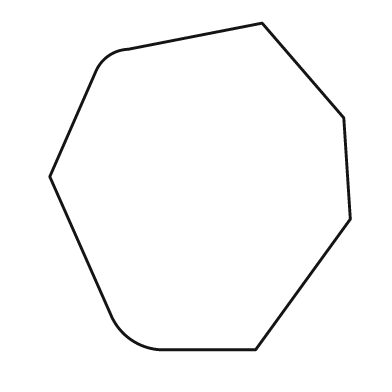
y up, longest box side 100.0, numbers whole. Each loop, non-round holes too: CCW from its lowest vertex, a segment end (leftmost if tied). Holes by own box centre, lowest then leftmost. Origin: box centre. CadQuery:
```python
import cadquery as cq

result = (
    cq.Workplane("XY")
    .moveTo(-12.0, -50.0)
    .lineTo(17.0, -50.0)
    .lineTo(46.0, -10.0)
    .lineTo(44.0, 21.0)
    .lineTo(19.0, 50.0)
    .lineTo(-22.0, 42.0)
    .threePointArc((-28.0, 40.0), (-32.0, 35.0))
    .lineTo(-46.0, 3.0)
    .lineTo(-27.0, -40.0)
    .threePointArc((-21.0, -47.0), (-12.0, -50.0))
    .close()
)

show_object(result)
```